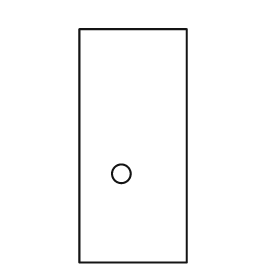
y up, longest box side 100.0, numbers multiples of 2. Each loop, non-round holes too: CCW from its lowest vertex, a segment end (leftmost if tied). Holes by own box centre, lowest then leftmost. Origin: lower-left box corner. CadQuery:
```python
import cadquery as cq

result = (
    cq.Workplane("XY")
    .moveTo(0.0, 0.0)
    .lineTo(46.0, 0.0)
    .lineTo(46.0, 100.0)
    .lineTo(0.0, 100.0)
    .close()
    .moveTo(18.0, 38.0)
    .circle(4.0)
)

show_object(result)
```